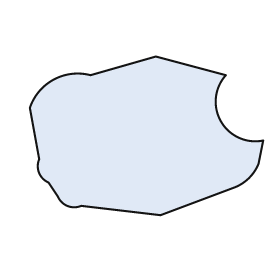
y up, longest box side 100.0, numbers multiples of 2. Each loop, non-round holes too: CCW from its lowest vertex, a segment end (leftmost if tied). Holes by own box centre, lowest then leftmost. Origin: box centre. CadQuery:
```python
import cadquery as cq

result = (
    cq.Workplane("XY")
    .moveTo(6.0, -34.0)
    .lineTo(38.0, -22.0)
    .threePointArc((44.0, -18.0), (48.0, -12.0))
    .lineTo(50.0, -2.0)
    .threePointArc((32.0, 6.0), (34.0, 26.0))
    .lineTo(4.0, 34.0)
    .lineTo(-24.0, 26.0)
    .threePointArc((-40.0, 24.0), (-50.0, 12.0))
    .lineTo(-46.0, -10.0)
    .threePointArc((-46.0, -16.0), (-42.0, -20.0))
    .lineTo(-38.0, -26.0)
    .threePointArc((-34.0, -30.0), (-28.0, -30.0))
    .close()
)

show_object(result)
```